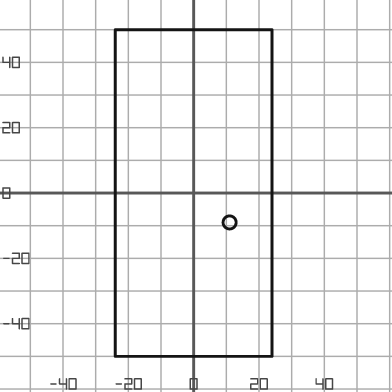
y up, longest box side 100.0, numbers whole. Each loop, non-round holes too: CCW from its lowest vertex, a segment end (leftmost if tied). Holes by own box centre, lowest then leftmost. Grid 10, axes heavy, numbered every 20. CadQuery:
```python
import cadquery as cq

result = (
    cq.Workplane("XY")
    .moveTo(-24.0, -50.0)
    .lineTo(24.0, -50.0)
    .lineTo(24.0, 50.0)
    .lineTo(-24.0, 50.0)
    .close()
    .moveTo(11.0, -9.0)
    .circle(2.0)
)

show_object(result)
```